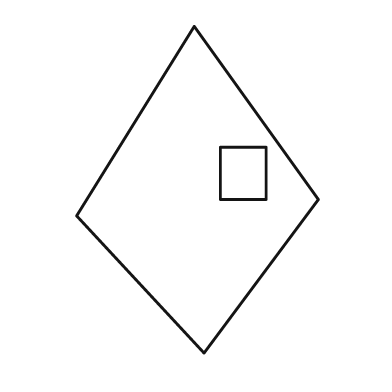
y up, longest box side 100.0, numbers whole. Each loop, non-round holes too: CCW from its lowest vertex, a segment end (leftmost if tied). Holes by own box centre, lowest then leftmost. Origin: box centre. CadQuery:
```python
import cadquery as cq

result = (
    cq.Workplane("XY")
    .moveTo(2.0, -50.0)
    .lineTo(37.0, -3.0)
    .lineTo(-1.0, 50.0)
    .lineTo(-37.0, -8.0)
    .close()
    .moveTo(7.0, -3.0)
    .lineTo(21.0, -3.0)
    .lineTo(21.0, 13.0)
    .lineTo(7.0, 13.0)
    .close()
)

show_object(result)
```